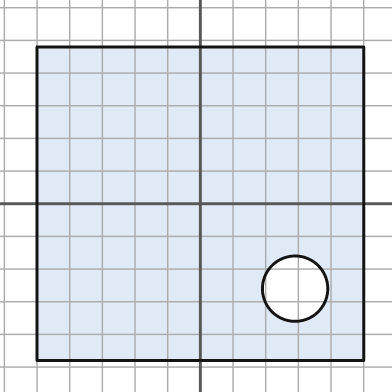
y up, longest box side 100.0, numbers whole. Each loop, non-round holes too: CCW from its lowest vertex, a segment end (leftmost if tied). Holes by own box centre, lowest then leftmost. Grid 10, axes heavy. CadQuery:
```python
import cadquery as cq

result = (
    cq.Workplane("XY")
    .moveTo(-50.0, -48.0)
    .lineTo(50.0, -48.0)
    .lineTo(50.0, 48.0)
    .lineTo(-50.0, 48.0)
    .close()
    .moveTo(29.0, -26.0)
    .circle(10.0)
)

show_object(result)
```